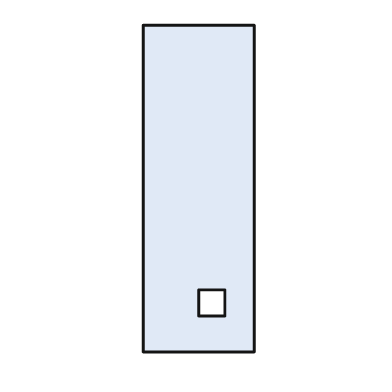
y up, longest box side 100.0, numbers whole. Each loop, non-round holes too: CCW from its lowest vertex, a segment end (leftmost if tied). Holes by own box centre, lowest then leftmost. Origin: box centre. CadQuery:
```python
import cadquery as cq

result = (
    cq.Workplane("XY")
    .moveTo(-17.0, -50.0)
    .lineTo(17.0, -50.0)
    .lineTo(17.0, 50.0)
    .lineTo(-17.0, 50.0)
    .close()
    .moveTo(0.0, -39.0)
    .lineTo(8.0, -39.0)
    .lineTo(8.0, -31.0)
    .lineTo(0.0, -31.0)
    .close()
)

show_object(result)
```